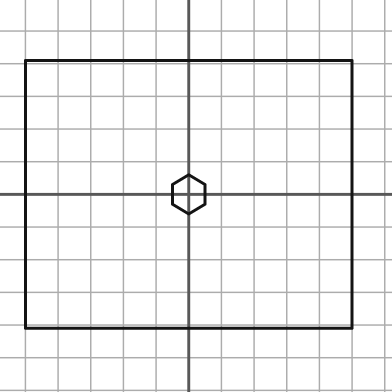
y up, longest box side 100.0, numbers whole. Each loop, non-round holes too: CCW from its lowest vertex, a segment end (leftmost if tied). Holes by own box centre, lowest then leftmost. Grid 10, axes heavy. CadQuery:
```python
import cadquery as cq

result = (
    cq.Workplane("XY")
    .moveTo(-50.0, -41.0)
    .lineTo(50.0, -41.0)
    .lineTo(50.0, 41.0)
    .lineTo(-50.0, 41.0)
    .close()
    .moveTo(0.0, -6.0)
    .lineTo(5.0, -3.0)
    .lineTo(5.0, 3.0)
    .lineTo(0.0, 6.0)
    .lineTo(-5.0, 3.0)
    .lineTo(-5.0, -3.0)
    .close()
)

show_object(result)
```